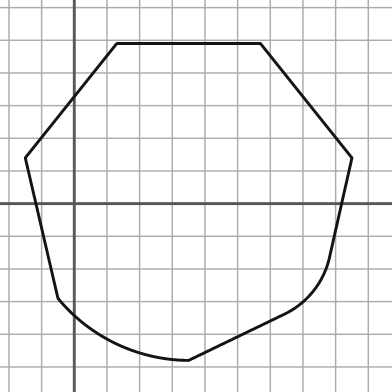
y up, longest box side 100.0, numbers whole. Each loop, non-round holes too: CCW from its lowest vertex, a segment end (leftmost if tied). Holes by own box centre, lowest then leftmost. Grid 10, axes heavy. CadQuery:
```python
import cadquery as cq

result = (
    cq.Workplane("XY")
    .moveTo(35.0, -48.0)
    .lineTo(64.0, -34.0)
    .threePointArc((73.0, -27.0), (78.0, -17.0))
    .lineTo(85.0, 14.0)
    .lineTo(57.0, 49.0)
    .lineTo(13.0, 49.0)
    .lineTo(-15.0, 14.0)
    .lineTo(-5.0, -29.0)
    .threePointArc((13.0, -43.0), (35.0, -48.0))
    .close()
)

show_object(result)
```